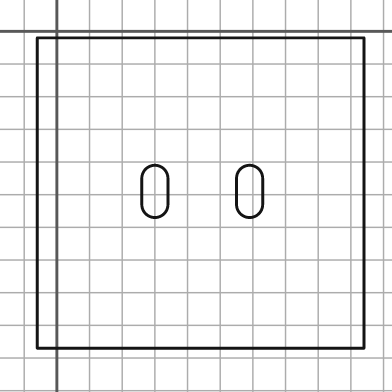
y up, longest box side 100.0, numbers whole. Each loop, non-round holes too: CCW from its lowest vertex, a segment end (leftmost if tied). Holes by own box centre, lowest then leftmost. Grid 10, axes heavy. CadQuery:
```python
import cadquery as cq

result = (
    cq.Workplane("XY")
    .moveTo(-6.0, -97.0)
    .lineTo(94.0, -97.0)
    .lineTo(94.0, -2.0)
    .lineTo(-6.0, -2.0)
    .close()
    .moveTo(26.0, -53.0)
    .threePointArc((30.0, -57.0), (34.0, -53.0))
    .lineTo(34.0, -45.0)
    .threePointArc((30.0, -41.0), (26.0, -45.0))
    .close()
    .moveTo(55.0, -53.0)
    .threePointArc((59.0, -57.0), (63.0, -53.0))
    .lineTo(63.0, -45.0)
    .threePointArc((59.0, -41.0), (55.0, -45.0))
    .close()
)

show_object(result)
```